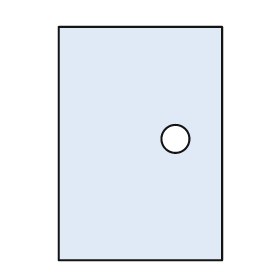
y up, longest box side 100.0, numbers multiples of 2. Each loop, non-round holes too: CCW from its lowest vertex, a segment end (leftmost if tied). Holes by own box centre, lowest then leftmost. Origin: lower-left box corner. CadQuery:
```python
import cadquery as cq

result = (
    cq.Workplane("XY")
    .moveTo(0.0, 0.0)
    .lineTo(70.0, 0.0)
    .lineTo(70.0, 100.0)
    .lineTo(0.0, 100.0)
    .close()
    .moveTo(50.0, 52.0)
    .circle(6.0)
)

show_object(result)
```